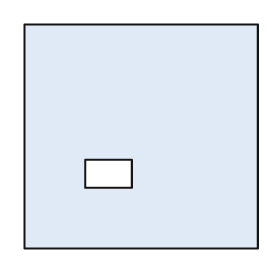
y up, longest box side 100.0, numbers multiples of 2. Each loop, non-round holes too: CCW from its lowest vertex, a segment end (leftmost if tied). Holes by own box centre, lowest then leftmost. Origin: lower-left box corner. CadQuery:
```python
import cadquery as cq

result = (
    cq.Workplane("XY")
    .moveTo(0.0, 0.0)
    .lineTo(100.0, 0.0)
    .lineTo(100.0, 96.0)
    .lineTo(0.0, 96.0)
    .close()
    .moveTo(26.0, 26.0)
    .lineTo(46.0, 26.0)
    .lineTo(46.0, 38.0)
    .lineTo(26.0, 38.0)
    .close()
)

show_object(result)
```